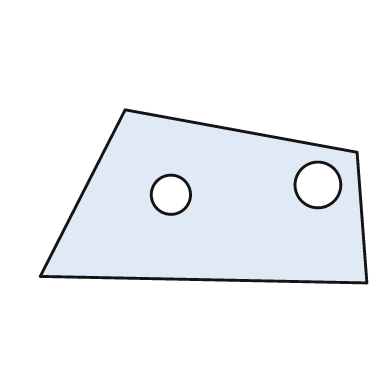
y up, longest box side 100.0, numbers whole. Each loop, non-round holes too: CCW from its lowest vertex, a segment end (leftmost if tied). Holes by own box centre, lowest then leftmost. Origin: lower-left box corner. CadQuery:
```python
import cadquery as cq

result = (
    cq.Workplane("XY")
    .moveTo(100.0, 0.0)
    .lineTo(97.0, 40.0)
    .lineTo(26.0, 53.0)
    .lineTo(0.0, 2.0)
    .close()
    .moveTo(40.0, 27.0)
    .circle(6.0)
    .moveTo(85.0, 30.0)
    .circle(7.0)
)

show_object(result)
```